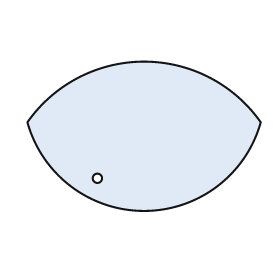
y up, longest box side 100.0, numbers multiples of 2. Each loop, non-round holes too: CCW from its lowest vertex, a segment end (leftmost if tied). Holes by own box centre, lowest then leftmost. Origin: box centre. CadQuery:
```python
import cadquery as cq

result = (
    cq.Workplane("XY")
    .moveTo(-50.0, 6.0)
    .threePointArc((0.0, -32.0), (50.0, 6.0))
    .threePointArc((0.0, 32.0), (-50.0, 6.0))
    .close()
    .moveTo(-20.0, -18.0)
    .circle(2.0)
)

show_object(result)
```